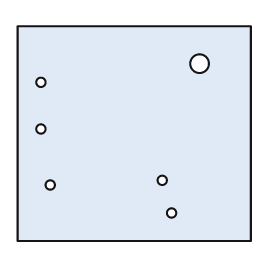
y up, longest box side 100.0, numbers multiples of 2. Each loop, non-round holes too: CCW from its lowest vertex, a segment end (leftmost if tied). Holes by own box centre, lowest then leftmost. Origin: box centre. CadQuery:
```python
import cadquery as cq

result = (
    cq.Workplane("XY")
    .moveTo(-50.0, -46.0)
    .lineTo(50.0, -46.0)
    .lineTo(50.0, 46.0)
    .lineTo(-50.0, 46.0)
    .close()
    .moveTo(16.0, -34.0)
    .circle(2.0)
    .moveTo(-36.0, -22.0)
    .circle(2.0)
    .moveTo(12.0, -20.0)
    .circle(2.0)
    .moveTo(-40.0, 2.0)
    .circle(2.0)
    .moveTo(-40.0, 22.0)
    .circle(2.0)
    .moveTo(28.0, 30.0)
    .circle(4.0)
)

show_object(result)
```